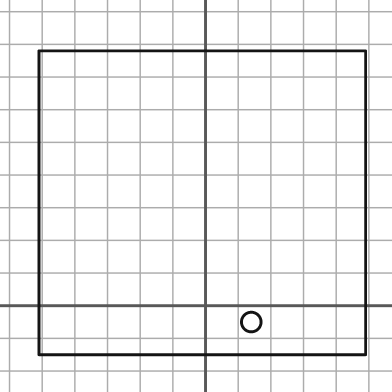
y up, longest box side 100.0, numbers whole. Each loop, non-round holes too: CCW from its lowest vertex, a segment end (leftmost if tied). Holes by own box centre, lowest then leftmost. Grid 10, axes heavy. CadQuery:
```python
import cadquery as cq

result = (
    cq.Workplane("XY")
    .moveTo(-51.0, -15.0)
    .lineTo(49.0, -15.0)
    .lineTo(49.0, 78.0)
    .lineTo(-51.0, 78.0)
    .close()
    .moveTo(14.0, -5.0)
    .circle(3.0)
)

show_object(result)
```